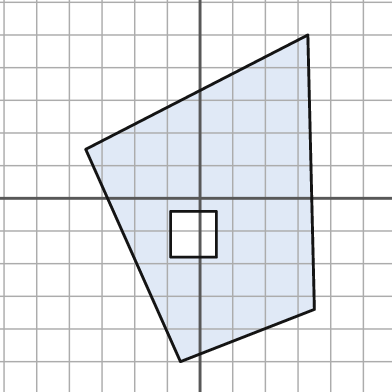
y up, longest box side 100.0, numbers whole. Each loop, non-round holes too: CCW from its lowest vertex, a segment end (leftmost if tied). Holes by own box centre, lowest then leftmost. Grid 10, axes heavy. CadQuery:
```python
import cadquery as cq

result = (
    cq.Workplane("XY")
    .moveTo(-6.0, -50.0)
    .lineTo(35.0, -34.0)
    .lineTo(33.0, 50.0)
    .lineTo(-35.0, 15.0)
    .close()
    .moveTo(-9.0, -18.0)
    .lineTo(5.0, -18.0)
    .lineTo(5.0, -4.0)
    .lineTo(-9.0, -4.0)
    .close()
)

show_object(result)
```